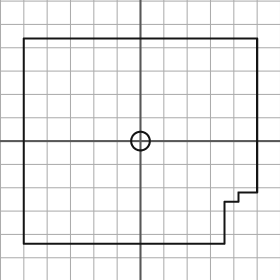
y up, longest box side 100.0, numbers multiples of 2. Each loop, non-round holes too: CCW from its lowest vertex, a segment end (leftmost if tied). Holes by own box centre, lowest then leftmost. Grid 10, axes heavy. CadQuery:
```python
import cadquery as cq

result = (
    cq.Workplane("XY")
    .moveTo(-50.0, -44.0)
    .lineTo(36.0, -44.0)
    .lineTo(36.0, -26.0)
    .lineTo(42.0, -26.0)
    .lineTo(42.0, -22.0)
    .lineTo(50.0, -22.0)
    .lineTo(50.0, 44.0)
    .lineTo(-50.0, 44.0)
    .close()
    .moveTo(0.0, 0.0)
    .circle(4.0)
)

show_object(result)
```